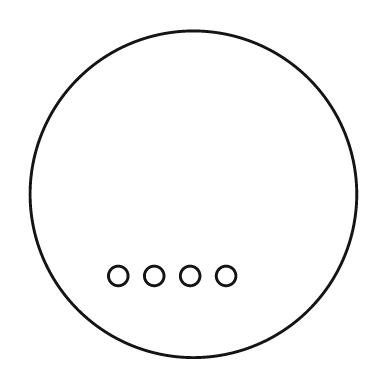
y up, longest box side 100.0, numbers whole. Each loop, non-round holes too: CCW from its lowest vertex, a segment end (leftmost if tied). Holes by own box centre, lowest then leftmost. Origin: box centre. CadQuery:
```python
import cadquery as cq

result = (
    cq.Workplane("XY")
    .moveTo(0.0, 0.0)
    .circle(50.0)
    .moveTo(-23.0, -25.0)
    .circle(3.0)
    .moveTo(-12.0, -25.0)
    .circle(3.0)
    .moveTo(-1.0, -25.0)
    .circle(3.0)
    .moveTo(10.0, -25.0)
    .circle(3.0)
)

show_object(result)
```